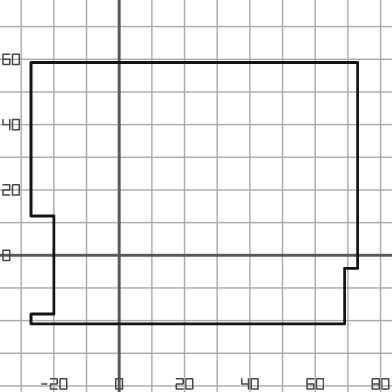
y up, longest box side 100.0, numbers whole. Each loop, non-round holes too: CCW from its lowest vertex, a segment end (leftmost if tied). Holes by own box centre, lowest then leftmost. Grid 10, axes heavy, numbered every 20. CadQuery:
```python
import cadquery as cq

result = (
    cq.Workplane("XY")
    .moveTo(-27.0, -21.0)
    .lineTo(69.0, -21.0)
    .lineTo(69.0, -4.0)
    .lineTo(73.0, -4.0)
    .lineTo(73.0, 59.0)
    .lineTo(-27.0, 59.0)
    .lineTo(-27.0, 12.0)
    .lineTo(-20.0, 12.0)
    .lineTo(-20.0, -18.0)
    .lineTo(-27.0, -18.0)
    .close()
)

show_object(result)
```